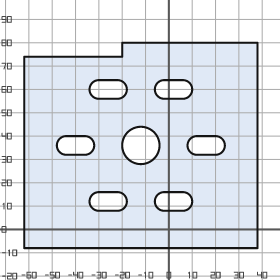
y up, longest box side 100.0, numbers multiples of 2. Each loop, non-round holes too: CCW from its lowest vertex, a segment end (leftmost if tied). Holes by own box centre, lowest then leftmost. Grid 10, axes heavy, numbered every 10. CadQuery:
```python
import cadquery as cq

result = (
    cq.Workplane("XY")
    .moveTo(-62.0, -8.0)
    .lineTo(38.0, -8.0)
    .lineTo(38.0, 80.0)
    .lineTo(-20.0, 80.0)
    .lineTo(-20.0, 74.0)
    .lineTo(-62.0, 74.0)
    .close()
    .moveTo(-30.0, 8.0)
    .lineTo(-22.0, 8.0)
    .threePointArc((-18.0, 12.0), (-22.0, 16.0))
    .lineTo(-30.0, 16.0)
    .threePointArc((-34.0, 12.0), (-30.0, 8.0))
    .close()
    .moveTo(-2.0, 8.0)
    .lineTo(6.0, 8.0)
    .threePointArc((10.0, 12.0), (6.0, 16.0))
    .lineTo(-2.0, 16.0)
    .threePointArc((-6.0, 12.0), (-2.0, 8.0))
    .close()
    .moveTo(-44.0, 32.0)
    .lineTo(-36.0, 32.0)
    .threePointArc((-32.0, 36.0), (-36.0, 40.0))
    .lineTo(-44.0, 40.0)
    .threePointArc((-48.0, 36.0), (-44.0, 32.0))
    .close()
    .moveTo(-12.0, 36.0)
    .circle(8.0)
    .moveTo(12.0, 32.0)
    .lineTo(20.0, 32.0)
    .threePointArc((24.0, 36.0), (20.0, 40.0))
    .lineTo(12.0, 40.0)
    .threePointArc((8.0, 36.0), (12.0, 32.0))
    .close()
    .moveTo(-30.0, 56.0)
    .lineTo(-22.0, 56.0)
    .threePointArc((-18.0, 60.0), (-22.0, 64.0))
    .lineTo(-30.0, 64.0)
    .threePointArc((-34.0, 60.0), (-30.0, 56.0))
    .close()
    .moveTo(-2.0, 56.0)
    .lineTo(6.0, 56.0)
    .threePointArc((10.0, 60.0), (6.0, 64.0))
    .lineTo(-2.0, 64.0)
    .threePointArc((-6.0, 60.0), (-2.0, 56.0))
    .close()
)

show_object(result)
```